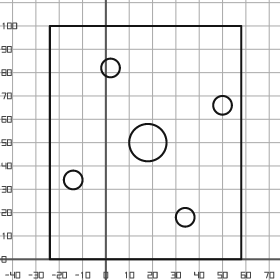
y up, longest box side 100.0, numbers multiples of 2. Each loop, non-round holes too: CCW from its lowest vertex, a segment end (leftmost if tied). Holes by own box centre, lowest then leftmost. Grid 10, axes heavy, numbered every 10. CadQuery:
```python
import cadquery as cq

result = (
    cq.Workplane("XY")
    .moveTo(-24.0, 0.0)
    .lineTo(58.0, 0.0)
    .lineTo(58.0, 100.0)
    .lineTo(-24.0, 100.0)
    .close()
    .moveTo(34.0, 18.0)
    .circle(4.0)
    .moveTo(-14.0, 34.0)
    .circle(4.0)
    .moveTo(18.0, 50.0)
    .circle(8.0)
    .moveTo(50.0, 66.0)
    .circle(4.0)
    .moveTo(2.0, 82.0)
    .circle(4.0)
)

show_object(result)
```